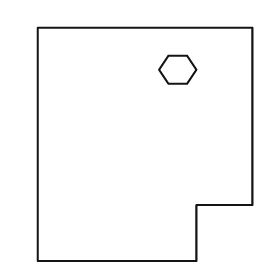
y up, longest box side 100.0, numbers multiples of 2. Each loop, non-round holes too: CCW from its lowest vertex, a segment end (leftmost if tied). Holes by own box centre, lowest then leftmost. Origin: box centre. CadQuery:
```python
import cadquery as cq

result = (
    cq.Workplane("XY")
    .moveTo(-46.0, -50.0)
    .lineTo(22.0, -50.0)
    .lineTo(22.0, -26.0)
    .lineTo(46.0, -26.0)
    .lineTo(46.0, 50.0)
    .lineTo(-46.0, 50.0)
    .close()
    .moveTo(10.0, 26.0)
    .lineTo(18.0, 26.0)
    .lineTo(22.0, 32.0)
    .lineTo(18.0, 38.0)
    .lineTo(10.0, 38.0)
    .lineTo(6.0, 32.0)
    .close()
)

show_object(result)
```